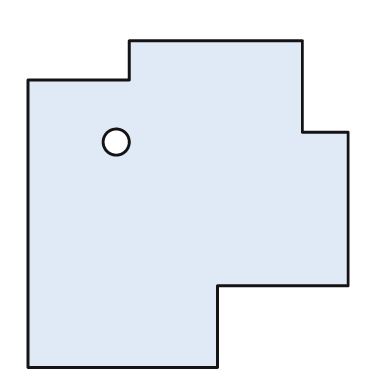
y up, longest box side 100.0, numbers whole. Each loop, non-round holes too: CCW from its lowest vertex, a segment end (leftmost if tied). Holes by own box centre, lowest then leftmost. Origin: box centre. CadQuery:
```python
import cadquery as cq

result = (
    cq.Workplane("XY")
    .moveTo(-49.0, -50.0)
    .lineTo(9.0, -50.0)
    .lineTo(9.0, -25.0)
    .lineTo(49.0, -25.0)
    .lineTo(49.0, 22.0)
    .lineTo(35.0, 22.0)
    .lineTo(35.0, 50.0)
    .lineTo(-18.0, 50.0)
    .lineTo(-18.0, 38.0)
    .lineTo(-49.0, 38.0)
    .close()
    .moveTo(-22.0, 19.0)
    .circle(4.0)
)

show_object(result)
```